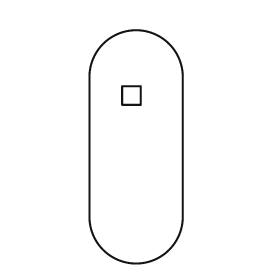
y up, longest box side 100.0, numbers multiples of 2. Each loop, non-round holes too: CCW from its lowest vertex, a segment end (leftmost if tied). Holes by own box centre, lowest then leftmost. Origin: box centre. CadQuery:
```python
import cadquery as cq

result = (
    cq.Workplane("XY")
    .moveTo(-20.0, -30.0)
    .threePointArc((0.0, -50.0), (20.0, -30.0))
    .lineTo(20.0, 30.0)
    .threePointArc((0.0, 50.0), (-20.0, 30.0))
    .close()
    .moveTo(-6.0, 18.0)
    .lineTo(2.0, 18.0)
    .lineTo(2.0, 26.0)
    .lineTo(-6.0, 26.0)
    .close()
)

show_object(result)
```